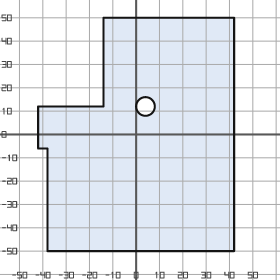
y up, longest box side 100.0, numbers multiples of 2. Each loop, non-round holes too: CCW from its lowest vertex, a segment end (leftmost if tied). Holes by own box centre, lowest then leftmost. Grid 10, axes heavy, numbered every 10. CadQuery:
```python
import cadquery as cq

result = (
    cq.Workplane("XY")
    .moveTo(-38.0, -50.0)
    .lineTo(42.0, -50.0)
    .lineTo(42.0, 50.0)
    .lineTo(-14.0, 50.0)
    .lineTo(-14.0, 12.0)
    .lineTo(-42.0, 12.0)
    .lineTo(-42.0, -6.0)
    .lineTo(-38.0, -6.0)
    .close()
    .moveTo(4.0, 12.0)
    .circle(4.0)
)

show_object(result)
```